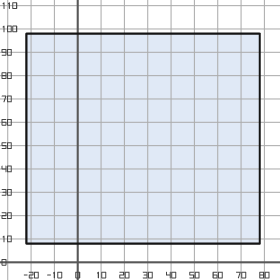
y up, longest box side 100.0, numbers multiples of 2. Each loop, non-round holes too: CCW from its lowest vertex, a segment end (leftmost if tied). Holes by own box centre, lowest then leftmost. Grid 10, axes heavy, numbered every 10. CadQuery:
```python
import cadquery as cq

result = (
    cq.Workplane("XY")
    .moveTo(-22.0, 8.0)
    .lineTo(78.0, 8.0)
    .lineTo(78.0, 98.0)
    .lineTo(-22.0, 98.0)
    .close()
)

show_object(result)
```